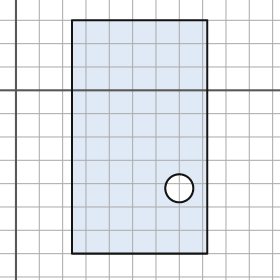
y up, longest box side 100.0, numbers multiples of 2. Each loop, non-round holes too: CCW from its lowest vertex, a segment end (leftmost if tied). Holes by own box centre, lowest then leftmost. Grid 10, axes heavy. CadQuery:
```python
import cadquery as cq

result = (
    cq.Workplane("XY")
    .moveTo(24.0, -70.0)
    .lineTo(82.0, -70.0)
    .lineTo(82.0, 30.0)
    .lineTo(24.0, 30.0)
    .close()
    .moveTo(70.0, -42.0)
    .circle(6.0)
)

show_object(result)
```